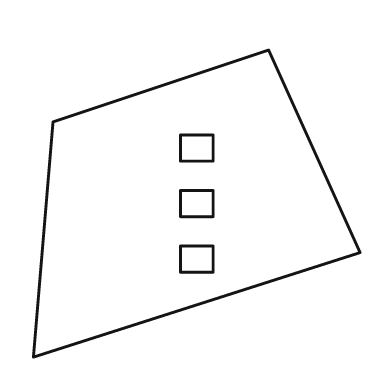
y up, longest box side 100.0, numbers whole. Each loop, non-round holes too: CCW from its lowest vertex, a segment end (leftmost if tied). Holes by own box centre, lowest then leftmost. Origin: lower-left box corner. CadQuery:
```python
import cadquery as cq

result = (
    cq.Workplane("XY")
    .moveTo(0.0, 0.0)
    .lineTo(100.0, 32.0)
    .lineTo(72.0, 94.0)
    .lineTo(6.0, 72.0)
    .close()
    .moveTo(45.0, 26.0)
    .lineTo(55.0, 26.0)
    .lineTo(55.0, 34.0)
    .lineTo(45.0, 34.0)
    .close()
    .moveTo(45.0, 43.0)
    .lineTo(55.0, 43.0)
    .lineTo(55.0, 51.0)
    .lineTo(45.0, 51.0)
    .close()
    .moveTo(45.0, 60.0)
    .lineTo(55.0, 60.0)
    .lineTo(55.0, 68.0)
    .lineTo(45.0, 68.0)
    .close()
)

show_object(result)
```